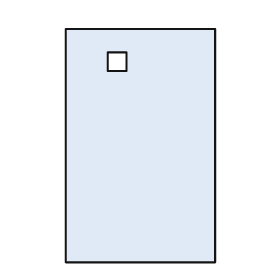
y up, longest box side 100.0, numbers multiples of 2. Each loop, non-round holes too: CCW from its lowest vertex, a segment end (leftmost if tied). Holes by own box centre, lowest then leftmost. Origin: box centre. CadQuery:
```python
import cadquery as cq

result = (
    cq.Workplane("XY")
    .moveTo(-32.0, -50.0)
    .lineTo(32.0, -50.0)
    .lineTo(32.0, 50.0)
    .lineTo(-32.0, 50.0)
    .close()
    .moveTo(-14.0, 32.0)
    .lineTo(-6.0, 32.0)
    .lineTo(-6.0, 40.0)
    .lineTo(-14.0, 40.0)
    .close()
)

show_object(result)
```